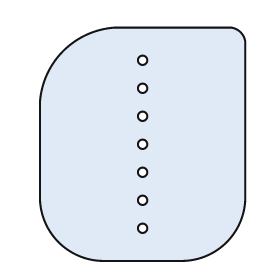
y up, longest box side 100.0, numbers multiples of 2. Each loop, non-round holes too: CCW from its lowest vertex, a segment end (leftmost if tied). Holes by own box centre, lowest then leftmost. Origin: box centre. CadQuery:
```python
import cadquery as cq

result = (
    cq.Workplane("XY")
    .moveTo(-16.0, -50.0)
    .lineTo(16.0, -50.0)
    .threePointArc((36.0, -42.0), (44.0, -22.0))
    .lineTo(44.0, 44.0)
    .threePointArc((42.0, 48.0), (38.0, 50.0))
    .lineTo(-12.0, 50.0)
    .threePointArc((-34.0, 40.0), (-44.0, 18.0))
    .lineTo(-44.0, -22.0)
    .threePointArc((-36.0, -42.0), (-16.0, -50.0))
    .close()
    .moveTo(0.0, -36.0)
    .circle(2.0)
    .moveTo(0.0, -24.0)
    .circle(2.0)
    .moveTo(0.0, -12.0)
    .circle(2.0)
    .moveTo(0.0, 0.0)
    .circle(2.0)
    .moveTo(0.0, 12.0)
    .circle(2.0)
    .moveTo(0.0, 24.0)
    .circle(2.0)
    .moveTo(0.0, 36.0)
    .circle(2.0)
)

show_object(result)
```